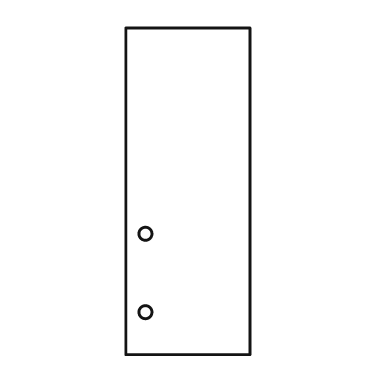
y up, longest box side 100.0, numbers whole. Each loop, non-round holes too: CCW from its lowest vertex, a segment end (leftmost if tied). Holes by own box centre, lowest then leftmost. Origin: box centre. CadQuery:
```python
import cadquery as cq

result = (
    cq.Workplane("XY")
    .moveTo(-19.0, -50.0)
    .lineTo(19.0, -50.0)
    .lineTo(19.0, 50.0)
    .lineTo(-19.0, 50.0)
    .close()
    .moveTo(-13.0, -37.0)
    .circle(2.0)
    .moveTo(-13.0, -13.0)
    .circle(2.0)
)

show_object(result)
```